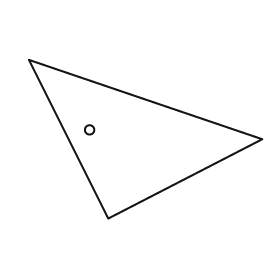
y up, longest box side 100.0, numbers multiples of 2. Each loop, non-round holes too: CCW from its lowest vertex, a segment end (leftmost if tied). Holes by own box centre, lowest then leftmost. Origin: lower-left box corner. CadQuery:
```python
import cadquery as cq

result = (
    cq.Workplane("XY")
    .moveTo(34.0, 0.0)
    .lineTo(100.0, 34.0)
    .lineTo(0.0, 68.0)
    .close()
    .moveTo(26.0, 38.0)
    .circle(2.0)
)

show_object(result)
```